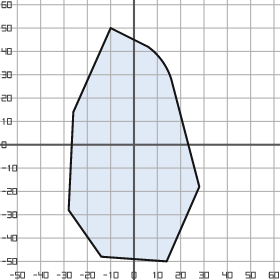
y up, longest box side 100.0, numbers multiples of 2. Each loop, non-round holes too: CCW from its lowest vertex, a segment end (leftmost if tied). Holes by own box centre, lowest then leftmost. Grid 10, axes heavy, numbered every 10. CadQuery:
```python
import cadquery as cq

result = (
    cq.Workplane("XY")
    .moveTo(14.0, -50.0)
    .lineTo(28.0, -18.0)
    .lineTo(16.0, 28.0)
    .threePointArc((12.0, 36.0), (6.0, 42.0))
    .lineTo(-10.0, 50.0)
    .lineTo(-26.0, 14.0)
    .lineTo(-28.0, -28.0)
    .lineTo(-14.0, -48.0)
    .close()
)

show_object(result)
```